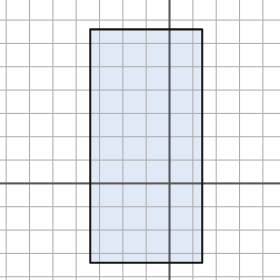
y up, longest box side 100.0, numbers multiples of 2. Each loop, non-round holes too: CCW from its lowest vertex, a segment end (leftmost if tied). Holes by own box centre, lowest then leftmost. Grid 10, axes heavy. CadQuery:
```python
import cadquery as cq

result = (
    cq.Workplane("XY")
    .moveTo(-34.0, -34.0)
    .lineTo(14.0, -34.0)
    .lineTo(14.0, 66.0)
    .lineTo(-34.0, 66.0)
    .close()
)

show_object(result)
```